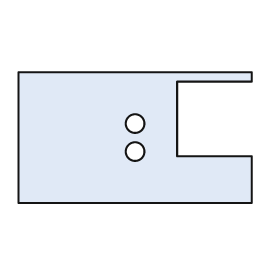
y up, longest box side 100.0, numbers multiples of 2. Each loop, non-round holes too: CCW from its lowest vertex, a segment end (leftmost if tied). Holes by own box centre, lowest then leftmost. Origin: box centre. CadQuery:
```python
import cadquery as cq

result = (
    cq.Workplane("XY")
    .moveTo(-50.0, -28.0)
    .lineTo(50.0, -28.0)
    .lineTo(50.0, -8.0)
    .lineTo(18.0, -8.0)
    .lineTo(18.0, 24.0)
    .lineTo(50.0, 24.0)
    .lineTo(50.0, 28.0)
    .lineTo(-50.0, 28.0)
    .close()
    .moveTo(0.0, -6.0)
    .circle(4.0)
    .moveTo(0.0, 6.0)
    .circle(4.0)
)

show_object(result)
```